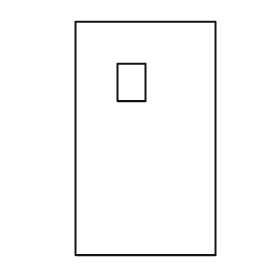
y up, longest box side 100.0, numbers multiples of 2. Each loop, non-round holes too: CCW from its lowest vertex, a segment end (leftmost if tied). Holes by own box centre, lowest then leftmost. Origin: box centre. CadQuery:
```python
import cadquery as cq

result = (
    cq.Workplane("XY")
    .moveTo(-30.0, -50.0)
    .lineTo(30.0, -50.0)
    .lineTo(30.0, 50.0)
    .lineTo(-30.0, 50.0)
    .close()
    .moveTo(-12.0, 16.0)
    .lineTo(0.0, 16.0)
    .lineTo(0.0, 32.0)
    .lineTo(-12.0, 32.0)
    .close()
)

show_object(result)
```